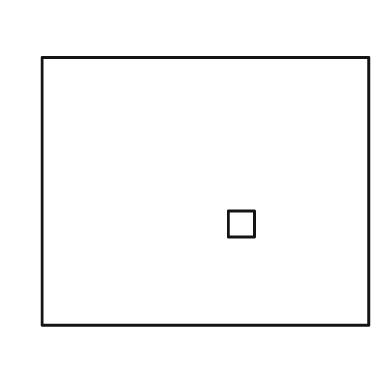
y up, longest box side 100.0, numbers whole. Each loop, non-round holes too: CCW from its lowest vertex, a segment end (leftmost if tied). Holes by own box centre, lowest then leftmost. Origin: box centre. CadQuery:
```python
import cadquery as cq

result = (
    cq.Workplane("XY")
    .moveTo(-50.0, -41.0)
    .lineTo(50.0, -41.0)
    .lineTo(50.0, 41.0)
    .lineTo(-50.0, 41.0)
    .close()
    .moveTo(7.0, -14.0)
    .lineTo(15.0, -14.0)
    .lineTo(15.0, -6.0)
    .lineTo(7.0, -6.0)
    .close()
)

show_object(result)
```